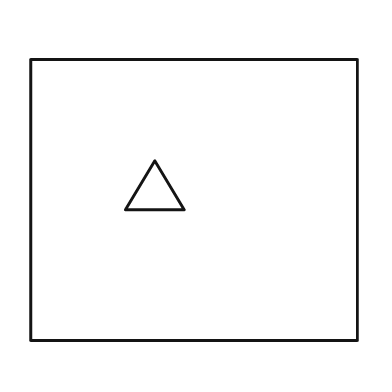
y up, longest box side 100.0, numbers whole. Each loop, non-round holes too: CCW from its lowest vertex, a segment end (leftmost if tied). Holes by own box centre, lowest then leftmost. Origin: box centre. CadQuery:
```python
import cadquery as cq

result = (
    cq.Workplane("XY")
    .moveTo(-50.0, -43.0)
    .lineTo(50.0, -43.0)
    .lineTo(50.0, 43.0)
    .lineTo(-50.0, 43.0)
    .close()
    .moveTo(-21.0, -3.0)
    .lineTo(-3.0, -3.0)
    .lineTo(-12.0, 12.0)
    .close()
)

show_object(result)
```